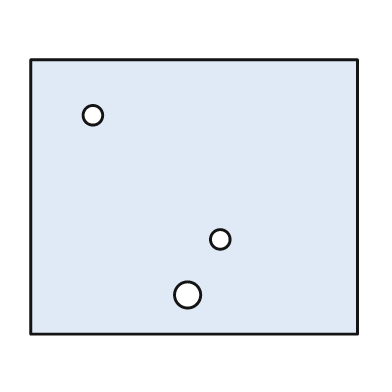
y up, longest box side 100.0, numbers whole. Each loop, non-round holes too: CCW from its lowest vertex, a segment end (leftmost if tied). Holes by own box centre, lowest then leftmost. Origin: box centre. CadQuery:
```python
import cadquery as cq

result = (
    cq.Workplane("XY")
    .moveTo(-50.0, -42.0)
    .lineTo(50.0, -42.0)
    .lineTo(50.0, 42.0)
    .lineTo(-50.0, 42.0)
    .close()
    .moveTo(-2.0, -30.0)
    .circle(4.0)
    .moveTo(8.0, -13.0)
    .circle(3.0)
    .moveTo(-31.0, 25.0)
    .circle(3.0)
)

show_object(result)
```